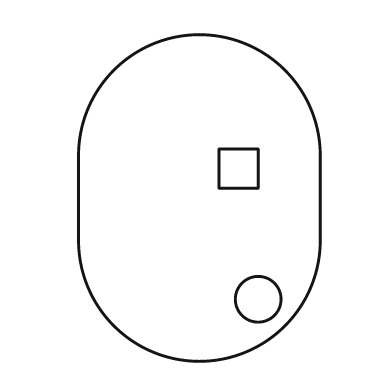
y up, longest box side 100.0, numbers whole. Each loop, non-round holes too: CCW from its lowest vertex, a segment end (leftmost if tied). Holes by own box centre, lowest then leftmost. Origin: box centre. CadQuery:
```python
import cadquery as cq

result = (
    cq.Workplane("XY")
    .moveTo(-37.0, -13.0)
    .threePointArc((0.0, -50.0), (37.0, -13.0))
    .lineTo(37.0, 13.0)
    .threePointArc((0.0, 50.0), (-37.0, 13.0))
    .close()
    .moveTo(18.0, -31.0)
    .circle(7.0)
    .moveTo(6.0, 3.0)
    .lineTo(18.0, 3.0)
    .lineTo(18.0, 15.0)
    .lineTo(6.0, 15.0)
    .close()
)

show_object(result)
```